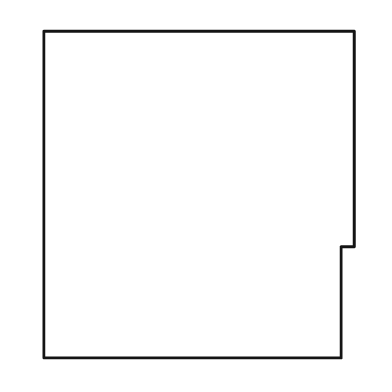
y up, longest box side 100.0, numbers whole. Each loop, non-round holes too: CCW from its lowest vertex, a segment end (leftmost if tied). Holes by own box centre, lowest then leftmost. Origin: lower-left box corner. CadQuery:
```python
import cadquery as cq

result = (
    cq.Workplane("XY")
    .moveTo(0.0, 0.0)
    .lineTo(91.0, 0.0)
    .lineTo(91.0, 34.0)
    .lineTo(95.0, 34.0)
    .lineTo(95.0, 100.0)
    .lineTo(0.0, 100.0)
    .close()
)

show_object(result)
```